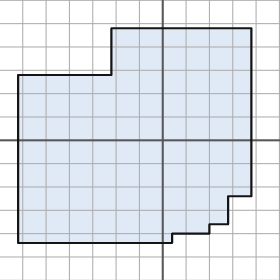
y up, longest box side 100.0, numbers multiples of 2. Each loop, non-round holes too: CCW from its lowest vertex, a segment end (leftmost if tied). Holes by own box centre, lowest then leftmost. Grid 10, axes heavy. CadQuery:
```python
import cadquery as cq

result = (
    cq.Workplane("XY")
    .moveTo(-62.0, -44.0)
    .lineTo(4.0, -44.0)
    .lineTo(4.0, -40.0)
    .lineTo(20.0, -40.0)
    .lineTo(20.0, -36.0)
    .lineTo(28.0, -36.0)
    .lineTo(28.0, -24.0)
    .lineTo(38.0, -24.0)
    .lineTo(38.0, 48.0)
    .lineTo(-22.0, 48.0)
    .lineTo(-22.0, 28.0)
    .lineTo(-62.0, 28.0)
    .close()
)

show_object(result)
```